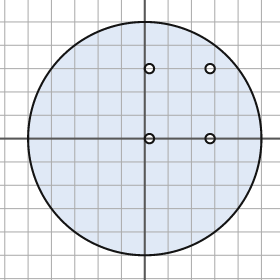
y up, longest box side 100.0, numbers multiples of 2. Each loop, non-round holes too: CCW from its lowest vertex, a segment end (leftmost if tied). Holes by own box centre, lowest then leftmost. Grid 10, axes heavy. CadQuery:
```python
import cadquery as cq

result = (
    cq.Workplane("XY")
    .moveTo(0.0, 0.0)
    .circle(50.0)
    .moveTo(2.0, 0.0)
    .circle(2.0)
    .moveTo(28.0, 0.0)
    .circle(2.0)
    .moveTo(2.0, 30.0)
    .circle(2.0)
    .moveTo(28.0, 30.0)
    .circle(2.0)
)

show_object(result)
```